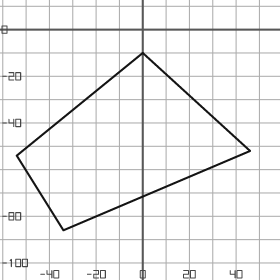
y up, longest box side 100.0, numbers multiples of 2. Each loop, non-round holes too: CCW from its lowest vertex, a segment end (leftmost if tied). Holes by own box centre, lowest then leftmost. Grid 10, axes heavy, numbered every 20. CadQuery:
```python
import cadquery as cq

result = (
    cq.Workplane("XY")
    .moveTo(-34.0, -86.0)
    .lineTo(46.0, -52.0)
    .lineTo(0.0, -10.0)
    .lineTo(-54.0, -54.0)
    .close()
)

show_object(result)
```